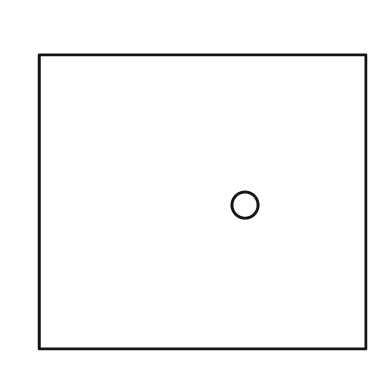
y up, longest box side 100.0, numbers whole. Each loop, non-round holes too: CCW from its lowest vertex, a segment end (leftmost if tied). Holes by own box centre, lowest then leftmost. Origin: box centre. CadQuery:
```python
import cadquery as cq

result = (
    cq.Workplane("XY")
    .moveTo(-50.0, -45.0)
    .lineTo(50.0, -45.0)
    .lineTo(50.0, 45.0)
    .lineTo(-50.0, 45.0)
    .close()
    .moveTo(13.0, -1.0)
    .circle(4.0)
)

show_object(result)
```